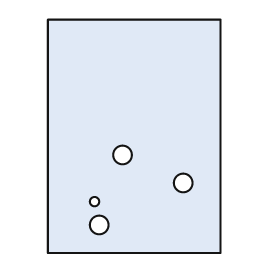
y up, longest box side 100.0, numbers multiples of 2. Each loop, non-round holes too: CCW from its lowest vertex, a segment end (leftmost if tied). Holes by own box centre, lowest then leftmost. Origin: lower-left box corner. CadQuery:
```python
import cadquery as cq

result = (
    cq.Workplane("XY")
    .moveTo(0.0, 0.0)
    .lineTo(74.0, 0.0)
    .lineTo(74.0, 100.0)
    .lineTo(0.0, 100.0)
    .close()
    .moveTo(22.0, 12.0)
    .circle(4.0)
    .moveTo(20.0, 22.0)
    .circle(2.0)
    .moveTo(58.0, 30.0)
    .circle(4.0)
    .moveTo(32.0, 42.0)
    .circle(4.0)
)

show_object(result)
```